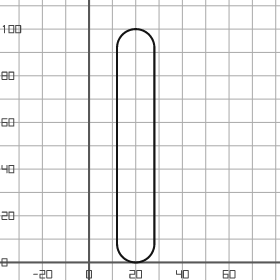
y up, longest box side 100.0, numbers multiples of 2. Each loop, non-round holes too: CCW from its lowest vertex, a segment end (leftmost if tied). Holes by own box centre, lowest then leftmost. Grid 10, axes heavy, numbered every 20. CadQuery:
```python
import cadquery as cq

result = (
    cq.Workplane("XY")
    .moveTo(12.0, 8.0)
    .threePointArc((20.0, 0.0), (28.0, 8.0))
    .lineTo(28.0, 92.0)
    .threePointArc((20.0, 100.0), (12.0, 92.0))
    .close()
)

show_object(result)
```